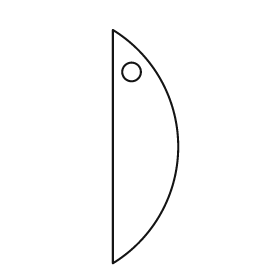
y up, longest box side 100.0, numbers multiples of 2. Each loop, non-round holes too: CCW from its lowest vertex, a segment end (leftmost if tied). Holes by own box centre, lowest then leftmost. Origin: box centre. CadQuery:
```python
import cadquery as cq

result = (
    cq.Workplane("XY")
    .moveTo(-14.0, -50.0)
    .threePointArc((14.0, 0.0), (-14.0, 50.0))
    .close()
    .moveTo(-6.0, 32.0)
    .circle(4.0)
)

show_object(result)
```